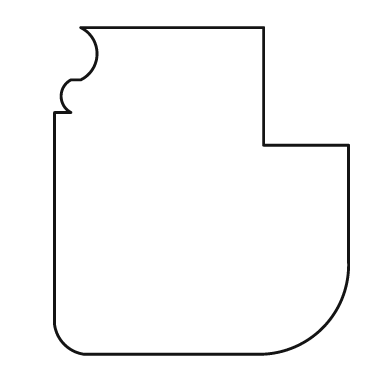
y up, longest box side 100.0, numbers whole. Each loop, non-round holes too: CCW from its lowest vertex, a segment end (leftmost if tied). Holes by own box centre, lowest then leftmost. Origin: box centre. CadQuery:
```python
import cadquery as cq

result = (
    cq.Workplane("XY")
    .moveTo(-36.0, -50.0)
    .lineTo(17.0, -50.0)
    .threePointArc((37.0, -42.0), (45.0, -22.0))
    .lineTo(45.0, 14.0)
    .lineTo(19.0, 14.0)
    .lineTo(19.0, 50.0)
    .lineTo(-37.0, 50.0)
    .threePointArc((-32.0, 42.0), (-37.0, 34.0))
    .lineTo(-40.0, 34.0)
    .threePointArc((-43.0, 29.0), (-40.0, 24.0))
    .lineTo(-45.0, 24.0)
    .lineTo(-45.0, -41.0)
    .threePointArc((-42.0, -47.0), (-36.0, -50.0))
    .close()
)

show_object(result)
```